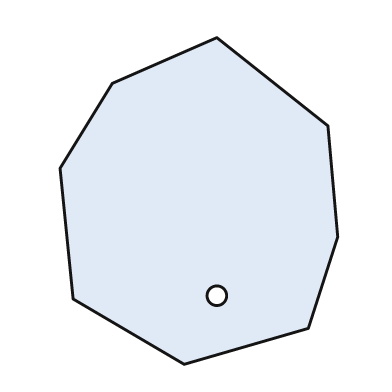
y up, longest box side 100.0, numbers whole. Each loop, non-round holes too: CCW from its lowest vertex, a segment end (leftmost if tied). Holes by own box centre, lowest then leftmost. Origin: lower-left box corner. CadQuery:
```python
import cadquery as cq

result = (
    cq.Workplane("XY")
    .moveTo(38.0, 0.0)
    .lineTo(76.0, 11.0)
    .lineTo(85.0, 39.0)
    .lineTo(82.0, 73.0)
    .lineTo(48.0, 100.0)
    .lineTo(16.0, 86.0)
    .lineTo(0.0, 60.0)
    .lineTo(4.0, 20.0)
    .close()
    .moveTo(48.0, 21.0)
    .circle(3.0)
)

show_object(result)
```